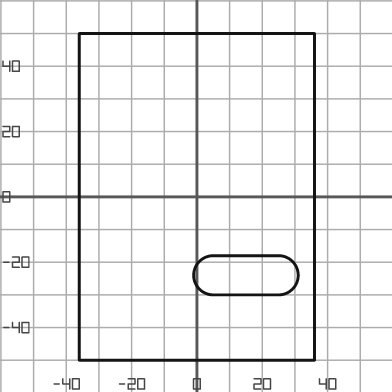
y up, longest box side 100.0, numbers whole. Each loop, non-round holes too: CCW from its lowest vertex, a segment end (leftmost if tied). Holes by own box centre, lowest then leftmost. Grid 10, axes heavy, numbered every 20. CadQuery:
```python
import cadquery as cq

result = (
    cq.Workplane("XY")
    .moveTo(-36.0, -50.0)
    .lineTo(36.0, -50.0)
    .lineTo(36.0, 50.0)
    .lineTo(-36.0, 50.0)
    .close()
    .moveTo(5.0, -30.0)
    .lineTo(25.0, -30.0)
    .threePointArc((31.0, -24.0), (25.0, -18.0))
    .lineTo(5.0, -18.0)
    .threePointArc((-1.0, -24.0), (5.0, -30.0))
    .close()
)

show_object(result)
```